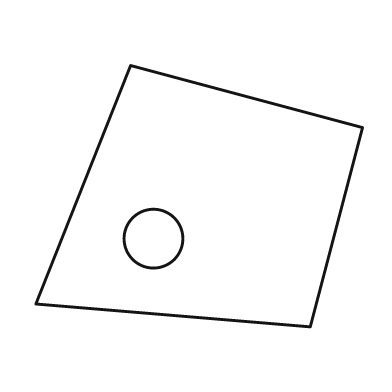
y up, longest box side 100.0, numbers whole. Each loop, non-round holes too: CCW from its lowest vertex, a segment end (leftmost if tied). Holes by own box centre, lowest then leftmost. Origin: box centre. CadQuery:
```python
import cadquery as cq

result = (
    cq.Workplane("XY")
    .moveTo(34.0, -40.0)
    .lineTo(50.0, 21.0)
    .lineTo(-21.0, 40.0)
    .lineTo(-50.0, -33.0)
    .close()
    .moveTo(-14.0, -13.0)
    .circle(9.0)
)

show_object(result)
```